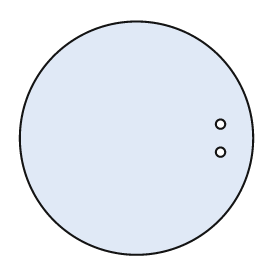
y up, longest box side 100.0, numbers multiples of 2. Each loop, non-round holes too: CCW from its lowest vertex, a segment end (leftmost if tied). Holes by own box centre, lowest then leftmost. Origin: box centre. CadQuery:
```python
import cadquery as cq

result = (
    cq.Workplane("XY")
    .moveTo(0.0, 0.0)
    .circle(50.0)
    .moveTo(36.0, -6.0)
    .circle(2.0)
    .moveTo(36.0, 6.0)
    .circle(2.0)
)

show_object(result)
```